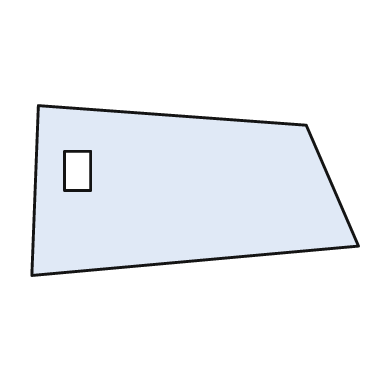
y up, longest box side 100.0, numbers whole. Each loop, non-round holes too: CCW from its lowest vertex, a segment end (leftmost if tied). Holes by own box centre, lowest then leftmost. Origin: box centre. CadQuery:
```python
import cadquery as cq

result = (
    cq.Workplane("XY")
    .moveTo(-50.0, -26.0)
    .lineTo(50.0, -17.0)
    .lineTo(34.0, 20.0)
    .lineTo(-48.0, 26.0)
    .close()
    .moveTo(-40.0, 0.0)
    .lineTo(-32.0, 0.0)
    .lineTo(-32.0, 12.0)
    .lineTo(-40.0, 12.0)
    .close()
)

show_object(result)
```